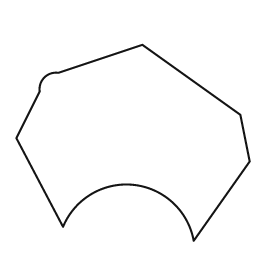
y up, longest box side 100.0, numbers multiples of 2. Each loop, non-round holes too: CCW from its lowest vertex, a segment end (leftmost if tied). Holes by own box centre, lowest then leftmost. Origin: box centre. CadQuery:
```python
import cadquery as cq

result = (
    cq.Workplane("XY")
    .moveTo(26.0, -42.0)
    .lineTo(50.0, -8.0)
    .lineTo(46.0, 12.0)
    .lineTo(4.0, 42.0)
    .lineTo(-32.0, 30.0)
    .threePointArc((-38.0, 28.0), (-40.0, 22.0))
    .lineTo(-50.0, 2.0)
    .lineTo(-30.0, -36.0)
    .threePointArc((0.0, -18.0), (26.0, -42.0))
    .close()
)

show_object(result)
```